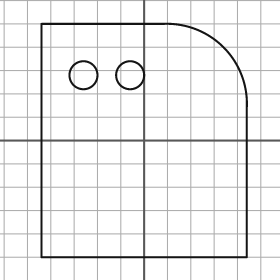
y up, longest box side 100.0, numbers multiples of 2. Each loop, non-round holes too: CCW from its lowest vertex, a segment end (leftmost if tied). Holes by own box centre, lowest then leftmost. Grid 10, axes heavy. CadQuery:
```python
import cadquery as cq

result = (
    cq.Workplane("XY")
    .moveTo(-44.0, -50.0)
    .lineTo(44.0, -50.0)
    .lineTo(44.0, 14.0)
    .threePointArc((34.0, 40.0), (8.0, 50.0))
    .lineTo(-44.0, 50.0)
    .close()
    .moveTo(-26.0, 28.0)
    .circle(6.0)
    .moveTo(-6.0, 28.0)
    .circle(6.0)
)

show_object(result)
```